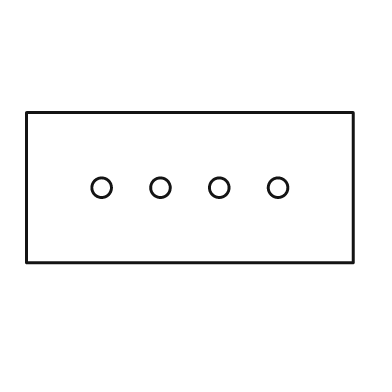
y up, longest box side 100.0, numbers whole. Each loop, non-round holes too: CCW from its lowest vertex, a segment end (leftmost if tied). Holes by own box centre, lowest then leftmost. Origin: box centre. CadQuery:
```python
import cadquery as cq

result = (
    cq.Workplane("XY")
    .moveTo(-50.0, -23.0)
    .lineTo(50.0, -23.0)
    .lineTo(50.0, 23.0)
    .lineTo(-50.0, 23.0)
    .close()
    .moveTo(-27.0, 0.0)
    .circle(3.0)
    .moveTo(-9.0, 0.0)
    .circle(3.0)
    .moveTo(9.0, 0.0)
    .circle(3.0)
    .moveTo(27.0, 0.0)
    .circle(3.0)
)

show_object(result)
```